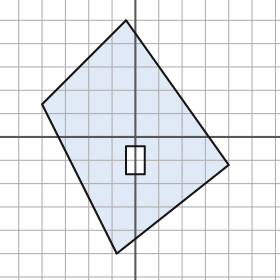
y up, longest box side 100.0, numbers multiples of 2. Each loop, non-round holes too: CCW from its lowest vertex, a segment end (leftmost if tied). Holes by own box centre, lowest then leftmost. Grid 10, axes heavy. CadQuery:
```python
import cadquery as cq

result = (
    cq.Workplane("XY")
    .moveTo(-8.0, -50.0)
    .lineTo(40.0, -12.0)
    .lineTo(-4.0, 50.0)
    .lineTo(-40.0, 14.0)
    .close()
    .moveTo(-4.0, -16.0)
    .lineTo(4.0, -16.0)
    .lineTo(4.0, -4.0)
    .lineTo(-4.0, -4.0)
    .close()
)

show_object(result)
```